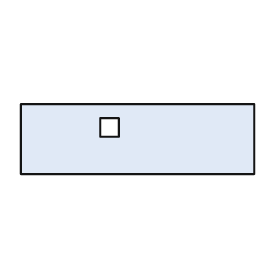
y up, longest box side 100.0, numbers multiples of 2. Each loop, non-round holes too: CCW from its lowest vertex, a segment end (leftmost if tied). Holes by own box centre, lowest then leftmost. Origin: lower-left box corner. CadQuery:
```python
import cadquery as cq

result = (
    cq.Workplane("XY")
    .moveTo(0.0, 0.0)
    .lineTo(100.0, 0.0)
    .lineTo(100.0, 30.0)
    .lineTo(0.0, 30.0)
    .close()
    .moveTo(34.0, 16.0)
    .lineTo(42.0, 16.0)
    .lineTo(42.0, 24.0)
    .lineTo(34.0, 24.0)
    .close()
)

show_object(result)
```